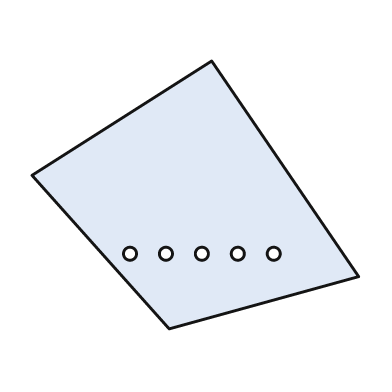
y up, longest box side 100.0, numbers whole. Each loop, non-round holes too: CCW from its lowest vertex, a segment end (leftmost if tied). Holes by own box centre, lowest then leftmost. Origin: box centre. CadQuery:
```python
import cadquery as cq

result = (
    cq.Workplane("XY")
    .moveTo(-8.0, -41.0)
    .lineTo(50.0, -25.0)
    .lineTo(5.0, 41.0)
    .lineTo(-50.0, 6.0)
    .close()
    .moveTo(-20.0, -18.0)
    .circle(2.0)
    .moveTo(-9.0, -18.0)
    .circle(2.0)
    .moveTo(2.0, -18.0)
    .circle(2.0)
    .moveTo(13.0, -18.0)
    .circle(2.0)
    .moveTo(24.0, -18.0)
    .circle(2.0)
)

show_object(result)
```